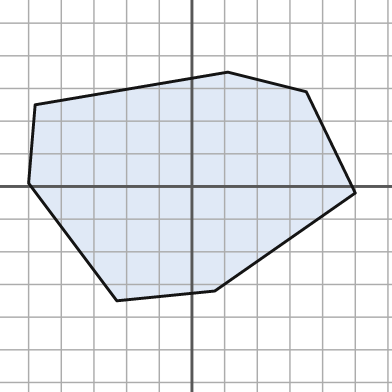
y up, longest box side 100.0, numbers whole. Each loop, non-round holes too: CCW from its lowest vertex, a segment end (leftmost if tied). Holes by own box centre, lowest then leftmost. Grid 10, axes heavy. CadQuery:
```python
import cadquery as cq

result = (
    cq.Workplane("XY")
    .moveTo(-23.0, -35.0)
    .lineTo(7.0, -32.0)
    .lineTo(50.0, -2.0)
    .lineTo(35.0, 29.0)
    .lineTo(11.0, 35.0)
    .lineTo(-48.0, 25.0)
    .lineTo(-50.0, 1.0)
    .close()
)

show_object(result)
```